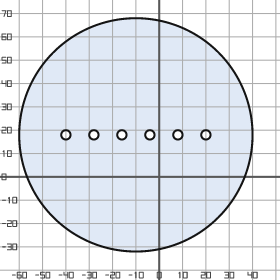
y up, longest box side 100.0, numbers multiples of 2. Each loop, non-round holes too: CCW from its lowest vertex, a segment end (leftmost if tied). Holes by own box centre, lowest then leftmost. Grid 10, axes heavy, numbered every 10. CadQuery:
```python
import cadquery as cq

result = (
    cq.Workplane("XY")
    .moveTo(-10.0, 18.0)
    .circle(50.0)
    .moveTo(-40.0, 18.0)
    .circle(2.0)
    .moveTo(-28.0, 18.0)
    .circle(2.0)
    .moveTo(-16.0, 18.0)
    .circle(2.0)
    .moveTo(-4.0, 18.0)
    .circle(2.0)
    .moveTo(8.0, 18.0)
    .circle(2.0)
    .moveTo(20.0, 18.0)
    .circle(2.0)
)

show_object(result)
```